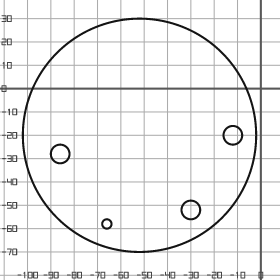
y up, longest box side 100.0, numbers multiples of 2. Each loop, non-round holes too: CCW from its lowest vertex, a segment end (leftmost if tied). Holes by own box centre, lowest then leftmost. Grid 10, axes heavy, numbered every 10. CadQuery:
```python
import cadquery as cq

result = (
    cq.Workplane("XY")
    .moveTo(-52.0, -20.0)
    .circle(50.0)
    .moveTo(-66.0, -58.0)
    .circle(2.0)
    .moveTo(-30.0, -52.0)
    .circle(4.0)
    .moveTo(-86.0, -28.0)
    .circle(4.0)
    .moveTo(-12.0, -20.0)
    .circle(4.0)
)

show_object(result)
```